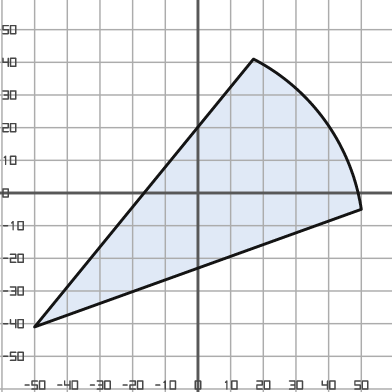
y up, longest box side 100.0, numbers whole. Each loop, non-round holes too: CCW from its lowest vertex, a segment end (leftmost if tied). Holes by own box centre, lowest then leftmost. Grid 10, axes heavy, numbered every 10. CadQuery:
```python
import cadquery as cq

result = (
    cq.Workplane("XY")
    .moveTo(-50.0, -41.0)
    .lineTo(50.0, -5.0)
    .threePointArc((39.0, 22.0), (17.0, 41.0))
    .close()
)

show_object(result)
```